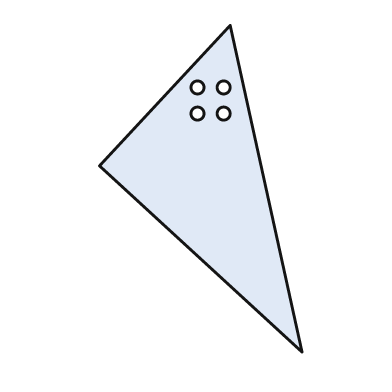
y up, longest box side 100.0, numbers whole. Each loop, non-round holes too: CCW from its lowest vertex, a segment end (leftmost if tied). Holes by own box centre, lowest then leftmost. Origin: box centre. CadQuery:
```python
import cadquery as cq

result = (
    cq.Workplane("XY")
    .moveTo(31.0, -50.0)
    .lineTo(9.0, 50.0)
    .lineTo(-31.0, 7.0)
    .close()
    .moveTo(-1.0, 23.0)
    .circle(2.0)
    .moveTo(7.0, 23.0)
    .circle(2.0)
    .moveTo(-1.0, 31.0)
    .circle(2.0)
    .moveTo(7.0, 31.0)
    .circle(2.0)
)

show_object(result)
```